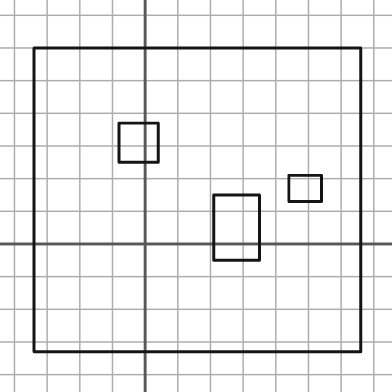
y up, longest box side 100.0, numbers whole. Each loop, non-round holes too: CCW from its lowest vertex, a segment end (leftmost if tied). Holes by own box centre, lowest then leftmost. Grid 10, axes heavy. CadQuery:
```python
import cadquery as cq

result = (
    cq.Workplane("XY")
    .moveTo(-34.0, -33.0)
    .lineTo(66.0, -33.0)
    .lineTo(66.0, 60.0)
    .lineTo(-34.0, 60.0)
    .close()
    .moveTo(21.0, -5.0)
    .lineTo(35.0, -5.0)
    .lineTo(35.0, 15.0)
    .lineTo(21.0, 15.0)
    .close()
    .moveTo(44.0, 13.0)
    .lineTo(54.0, 13.0)
    .lineTo(54.0, 21.0)
    .lineTo(44.0, 21.0)
    .close()
    .moveTo(-8.0, 25.0)
    .lineTo(4.0, 25.0)
    .lineTo(4.0, 37.0)
    .lineTo(-8.0, 37.0)
    .close()
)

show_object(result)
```